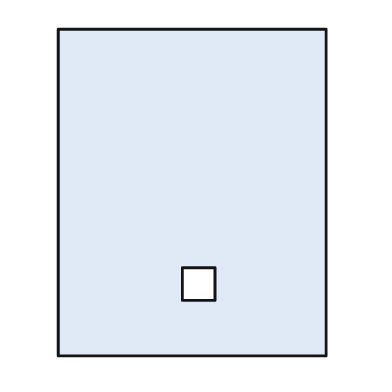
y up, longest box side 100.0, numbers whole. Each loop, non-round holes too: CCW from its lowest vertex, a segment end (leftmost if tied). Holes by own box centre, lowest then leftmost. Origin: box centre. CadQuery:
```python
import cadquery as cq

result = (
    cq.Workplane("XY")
    .moveTo(-41.0, -50.0)
    .lineTo(41.0, -50.0)
    .lineTo(41.0, 50.0)
    .lineTo(-41.0, 50.0)
    .close()
    .moveTo(-3.0, -33.0)
    .lineTo(7.0, -33.0)
    .lineTo(7.0, -23.0)
    .lineTo(-3.0, -23.0)
    .close()
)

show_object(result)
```